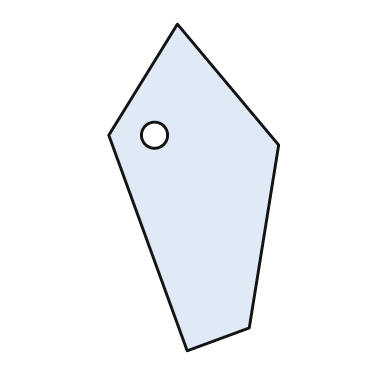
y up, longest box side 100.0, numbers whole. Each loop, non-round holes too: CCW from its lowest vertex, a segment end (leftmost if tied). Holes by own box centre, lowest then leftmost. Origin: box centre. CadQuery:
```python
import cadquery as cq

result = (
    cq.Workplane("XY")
    .moveTo(-2.0, -50.0)
    .lineTo(17.0, -43.0)
    .lineTo(26.0, 13.0)
    .lineTo(-5.0, 50.0)
    .lineTo(-26.0, 16.0)
    .close()
    .moveTo(-12.0, 16.0)
    .circle(4.0)
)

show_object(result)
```